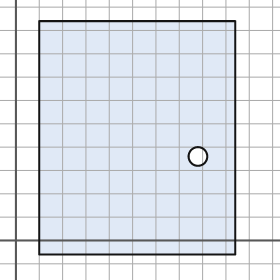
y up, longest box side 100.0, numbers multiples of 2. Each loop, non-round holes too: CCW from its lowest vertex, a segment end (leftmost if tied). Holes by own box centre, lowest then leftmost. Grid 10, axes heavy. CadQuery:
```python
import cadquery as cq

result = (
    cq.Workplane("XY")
    .moveTo(10.0, -6.0)
    .lineTo(94.0, -6.0)
    .lineTo(94.0, 94.0)
    .lineTo(10.0, 94.0)
    .close()
    .moveTo(78.0, 36.0)
    .circle(4.0)
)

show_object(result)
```